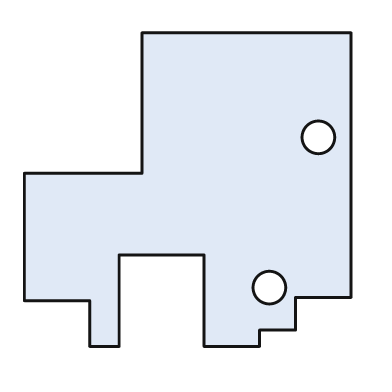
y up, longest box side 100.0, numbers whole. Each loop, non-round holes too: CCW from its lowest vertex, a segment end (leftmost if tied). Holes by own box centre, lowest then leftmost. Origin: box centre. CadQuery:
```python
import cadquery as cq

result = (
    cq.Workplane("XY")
    .moveTo(-30.0, -48.0)
    .lineTo(-21.0, -48.0)
    .lineTo(-21.0, -20.0)
    .lineTo(5.0, -20.0)
    .lineTo(5.0, -48.0)
    .lineTo(22.0, -48.0)
    .lineTo(22.0, -43.0)
    .lineTo(33.0, -43.0)
    .lineTo(33.0, -33.0)
    .lineTo(50.0, -33.0)
    .lineTo(50.0, 48.0)
    .lineTo(-14.0, 48.0)
    .lineTo(-14.0, 5.0)
    .lineTo(-50.0, 5.0)
    .lineTo(-50.0, -34.0)
    .lineTo(-30.0, -34.0)
    .close()
    .moveTo(25.0, -30.0)
    .circle(5.0)
    .moveTo(40.0, 16.0)
    .circle(5.0)
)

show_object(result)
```